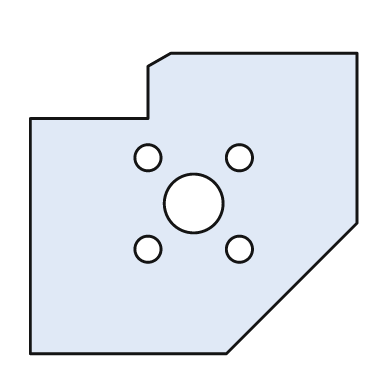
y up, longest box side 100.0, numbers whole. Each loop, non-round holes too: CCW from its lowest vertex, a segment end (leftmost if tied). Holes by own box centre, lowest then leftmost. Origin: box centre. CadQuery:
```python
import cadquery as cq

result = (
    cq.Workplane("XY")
    .moveTo(-50.0, -46.0)
    .lineTo(10.0, -46.0)
    .lineTo(50.0, -6.0)
    .lineTo(50.0, 46.0)
    .lineTo(-7.0, 46.0)
    .lineTo(-14.0, 42.0)
    .lineTo(-14.0, 26.0)
    .lineTo(-50.0, 26.0)
    .close()
    .moveTo(-14.0, -14.0)
    .circle(4.0)
    .moveTo(14.0, -14.0)
    .circle(4.0)
    .moveTo(0.0, 0.0)
    .circle(9.0)
    .moveTo(-14.0, 14.0)
    .circle(4.0)
    .moveTo(14.0, 14.0)
    .circle(4.0)
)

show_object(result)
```